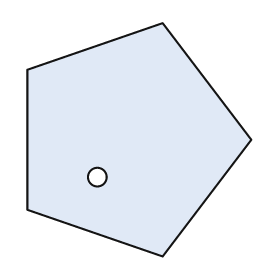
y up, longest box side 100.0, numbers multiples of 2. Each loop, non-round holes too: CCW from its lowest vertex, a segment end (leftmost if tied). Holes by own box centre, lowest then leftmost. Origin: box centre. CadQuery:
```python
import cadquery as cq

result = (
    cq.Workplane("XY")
    .moveTo(10.0, -50.0)
    .lineTo(48.0, 0.0)
    .lineTo(10.0, 50.0)
    .lineTo(-48.0, 30.0)
    .lineTo(-48.0, -30.0)
    .close()
    .moveTo(-18.0, -16.0)
    .circle(4.0)
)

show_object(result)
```